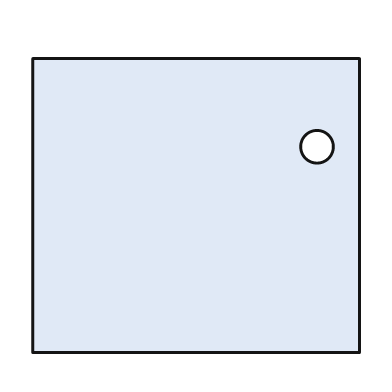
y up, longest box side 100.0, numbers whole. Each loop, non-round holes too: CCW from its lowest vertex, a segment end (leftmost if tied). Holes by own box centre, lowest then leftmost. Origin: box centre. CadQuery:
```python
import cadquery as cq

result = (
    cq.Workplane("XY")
    .moveTo(-50.0, -45.0)
    .lineTo(50.0, -45.0)
    .lineTo(50.0, 45.0)
    .lineTo(-50.0, 45.0)
    .close()
    .moveTo(37.0, 18.0)
    .circle(5.0)
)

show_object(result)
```